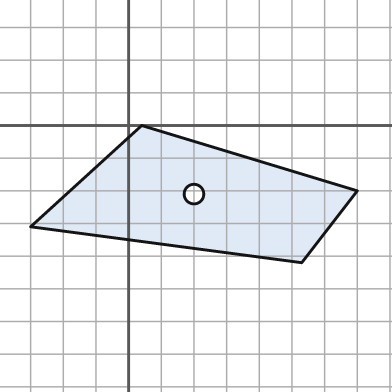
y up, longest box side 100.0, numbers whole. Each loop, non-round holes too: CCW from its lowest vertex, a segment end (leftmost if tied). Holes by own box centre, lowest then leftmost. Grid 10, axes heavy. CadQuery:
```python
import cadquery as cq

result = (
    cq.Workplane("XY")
    .moveTo(53.0, -42.0)
    .lineTo(70.0, -20.0)
    .lineTo(4.0, 0.0)
    .lineTo(-30.0, -31.0)
    .close()
    .moveTo(20.0, -21.0)
    .circle(3.0)
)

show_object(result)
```